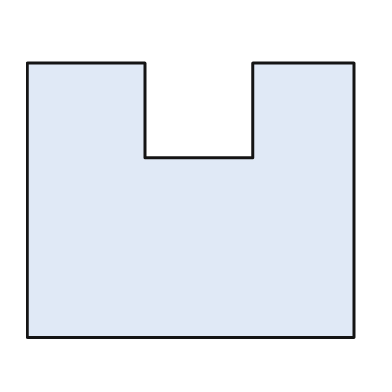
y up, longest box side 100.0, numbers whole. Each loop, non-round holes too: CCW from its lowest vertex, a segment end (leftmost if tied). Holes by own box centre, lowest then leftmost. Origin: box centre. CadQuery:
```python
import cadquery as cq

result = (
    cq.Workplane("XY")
    .moveTo(-50.0, -42.0)
    .lineTo(50.0, -42.0)
    .lineTo(50.0, 42.0)
    .lineTo(19.0, 42.0)
    .lineTo(19.0, 13.0)
    .lineTo(-14.0, 13.0)
    .lineTo(-14.0, 42.0)
    .lineTo(-50.0, 42.0)
    .close()
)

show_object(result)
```